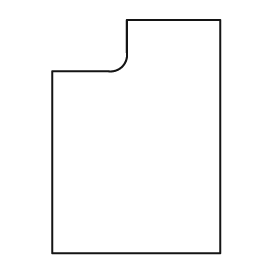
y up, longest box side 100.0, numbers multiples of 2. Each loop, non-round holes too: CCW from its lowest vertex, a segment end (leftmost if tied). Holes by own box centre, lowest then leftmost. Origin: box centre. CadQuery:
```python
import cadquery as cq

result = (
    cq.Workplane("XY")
    .moveTo(-36.0, -50.0)
    .lineTo(36.0, -50.0)
    .lineTo(36.0, 50.0)
    .lineTo(-4.0, 50.0)
    .lineTo(-4.0, 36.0)
    .threePointArc((-6.0, 30.0), (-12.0, 28.0))
    .lineTo(-36.0, 28.0)
    .close()
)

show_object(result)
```